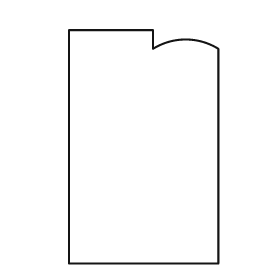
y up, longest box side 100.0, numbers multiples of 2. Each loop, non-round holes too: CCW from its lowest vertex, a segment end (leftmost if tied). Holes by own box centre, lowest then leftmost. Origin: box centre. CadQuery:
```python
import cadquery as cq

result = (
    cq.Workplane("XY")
    .moveTo(-32.0, -50.0)
    .lineTo(32.0, -50.0)
    .lineTo(32.0, 42.0)
    .threePointArc((18.0, 46.0), (4.0, 42.0))
    .lineTo(4.0, 50.0)
    .lineTo(-32.0, 50.0)
    .close()
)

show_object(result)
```